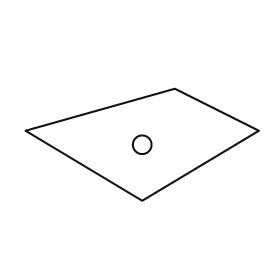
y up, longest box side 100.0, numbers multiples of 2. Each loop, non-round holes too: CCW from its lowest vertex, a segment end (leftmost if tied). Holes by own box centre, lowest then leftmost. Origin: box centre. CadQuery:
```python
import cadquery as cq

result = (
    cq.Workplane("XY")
    .moveTo(0.0, -24.0)
    .lineTo(50.0, 6.0)
    .lineTo(14.0, 24.0)
    .lineTo(-50.0, 6.0)
    .close()
    .moveTo(0.0, 0.0)
    .circle(4.0)
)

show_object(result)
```